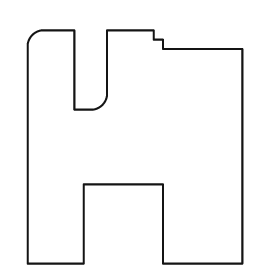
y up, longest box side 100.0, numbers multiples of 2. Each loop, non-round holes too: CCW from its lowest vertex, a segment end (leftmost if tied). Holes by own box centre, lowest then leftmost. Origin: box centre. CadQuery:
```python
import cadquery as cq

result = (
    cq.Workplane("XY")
    .moveTo(-46.0, -50.0)
    .lineTo(-22.0, -50.0)
    .lineTo(-22.0, -16.0)
    .lineTo(12.0, -16.0)
    .lineTo(12.0, -50.0)
    .lineTo(46.0, -50.0)
    .lineTo(46.0, 42.0)
    .lineTo(12.0, 42.0)
    .lineTo(12.0, 46.0)
    .lineTo(8.0, 46.0)
    .lineTo(8.0, 50.0)
    .lineTo(-12.0, 50.0)
    .lineTo(-12.0, 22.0)
    .threePointArc((-14.0, 18.0), (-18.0, 16.0))
    .lineTo(-26.0, 16.0)
    .lineTo(-26.0, 50.0)
    .lineTo(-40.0, 50.0)
    .threePointArc((-44.0, 48.0), (-46.0, 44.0))
    .close()
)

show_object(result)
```